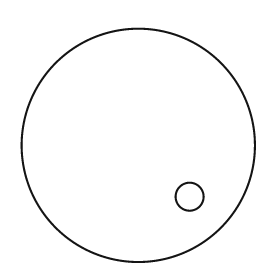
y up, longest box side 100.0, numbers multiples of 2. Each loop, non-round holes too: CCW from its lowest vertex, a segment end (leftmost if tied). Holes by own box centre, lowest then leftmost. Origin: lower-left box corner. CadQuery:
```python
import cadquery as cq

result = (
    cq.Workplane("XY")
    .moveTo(50.0, 50.0)
    .circle(50.0)
    .moveTo(72.0, 28.0)
    .circle(6.0)
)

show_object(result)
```